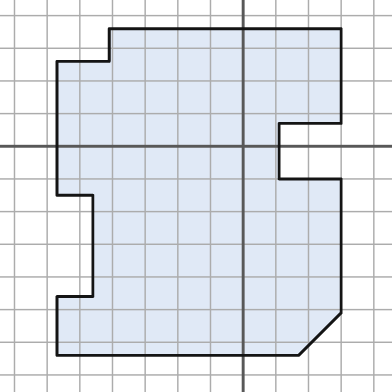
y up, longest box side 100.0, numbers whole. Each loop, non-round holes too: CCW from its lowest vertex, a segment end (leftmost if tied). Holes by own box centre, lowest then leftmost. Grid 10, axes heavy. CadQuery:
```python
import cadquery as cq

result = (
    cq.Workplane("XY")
    .moveTo(-57.0, -64.0)
    .lineTo(17.0, -64.0)
    .lineTo(30.0, -51.0)
    .lineTo(30.0, -10.0)
    .lineTo(11.0, -10.0)
    .lineTo(11.0, 7.0)
    .lineTo(30.0, 7.0)
    .lineTo(30.0, 36.0)
    .lineTo(-41.0, 36.0)
    .lineTo(-41.0, 26.0)
    .lineTo(-57.0, 26.0)
    .lineTo(-57.0, -15.0)
    .lineTo(-46.0, -15.0)
    .lineTo(-46.0, -46.0)
    .lineTo(-57.0, -46.0)
    .close()
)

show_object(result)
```